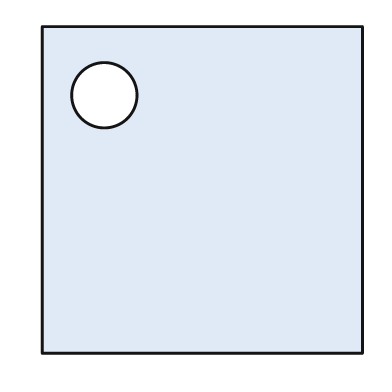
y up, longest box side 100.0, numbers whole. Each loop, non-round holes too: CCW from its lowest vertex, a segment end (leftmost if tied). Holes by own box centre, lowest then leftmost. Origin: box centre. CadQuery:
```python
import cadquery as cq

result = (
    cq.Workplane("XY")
    .moveTo(-49.0, -50.0)
    .lineTo(49.0, -50.0)
    .lineTo(49.0, 50.0)
    .lineTo(-49.0, 50.0)
    .close()
    .moveTo(-30.0, 29.0)
    .circle(10.0)
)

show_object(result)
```